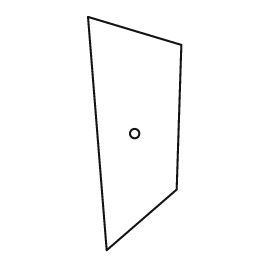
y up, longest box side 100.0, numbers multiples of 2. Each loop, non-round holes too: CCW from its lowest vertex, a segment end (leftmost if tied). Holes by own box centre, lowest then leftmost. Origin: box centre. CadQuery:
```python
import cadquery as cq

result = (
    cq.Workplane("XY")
    .moveTo(-12.0, -50.0)
    .lineTo(18.0, -24.0)
    .lineTo(20.0, 38.0)
    .lineTo(-20.0, 50.0)
    .close()
    .moveTo(0.0, 0.0)
    .circle(2.0)
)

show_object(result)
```